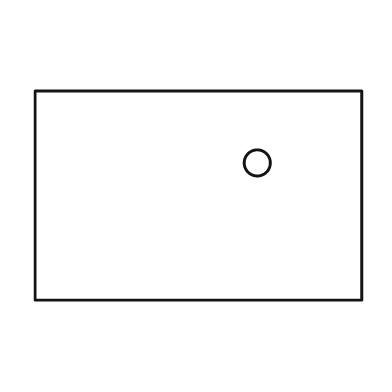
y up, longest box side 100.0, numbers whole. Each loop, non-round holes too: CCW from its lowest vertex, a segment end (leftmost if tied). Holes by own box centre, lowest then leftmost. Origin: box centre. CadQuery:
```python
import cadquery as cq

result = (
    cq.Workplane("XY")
    .moveTo(-50.0, -32.0)
    .lineTo(50.0, -32.0)
    .lineTo(50.0, 32.0)
    .lineTo(-50.0, 32.0)
    .close()
    .moveTo(18.0, 10.0)
    .circle(4.0)
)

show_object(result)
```